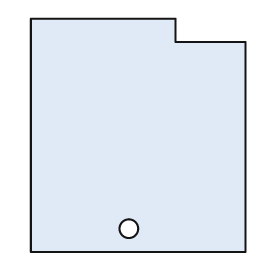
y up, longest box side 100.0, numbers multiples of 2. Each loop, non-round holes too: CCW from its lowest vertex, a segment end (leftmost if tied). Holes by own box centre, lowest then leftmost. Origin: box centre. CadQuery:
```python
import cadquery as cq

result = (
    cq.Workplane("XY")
    .moveTo(-46.0, -50.0)
    .lineTo(46.0, -50.0)
    .lineTo(46.0, 40.0)
    .lineTo(16.0, 40.0)
    .lineTo(16.0, 50.0)
    .lineTo(-46.0, 50.0)
    .close()
    .moveTo(-4.0, -40.0)
    .circle(4.0)
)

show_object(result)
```